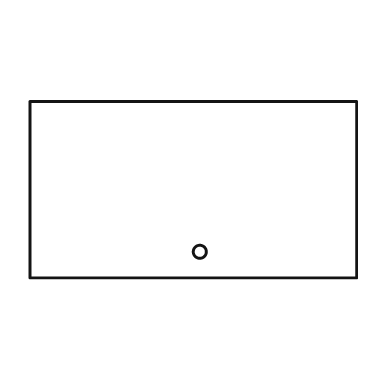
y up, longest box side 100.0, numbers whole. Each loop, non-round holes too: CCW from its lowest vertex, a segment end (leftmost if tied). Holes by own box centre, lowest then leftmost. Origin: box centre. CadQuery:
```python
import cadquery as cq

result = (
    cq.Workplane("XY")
    .moveTo(-50.0, -27.0)
    .lineTo(50.0, -27.0)
    .lineTo(50.0, 27.0)
    .lineTo(-50.0, 27.0)
    .close()
    .moveTo(2.0, -19.0)
    .circle(2.0)
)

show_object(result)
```